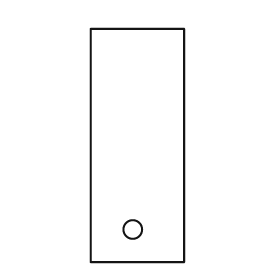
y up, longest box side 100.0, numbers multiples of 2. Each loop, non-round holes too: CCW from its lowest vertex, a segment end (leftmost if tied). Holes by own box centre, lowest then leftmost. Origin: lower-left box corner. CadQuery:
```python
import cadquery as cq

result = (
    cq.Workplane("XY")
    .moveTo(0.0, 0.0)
    .lineTo(40.0, 0.0)
    .lineTo(40.0, 100.0)
    .lineTo(0.0, 100.0)
    .close()
    .moveTo(18.0, 14.0)
    .circle(4.0)
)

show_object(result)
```